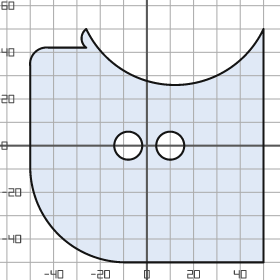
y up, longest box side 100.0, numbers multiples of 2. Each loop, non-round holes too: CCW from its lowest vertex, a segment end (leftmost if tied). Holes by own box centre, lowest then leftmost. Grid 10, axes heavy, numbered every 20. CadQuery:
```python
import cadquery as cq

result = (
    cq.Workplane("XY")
    .moveTo(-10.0, -50.0)
    .lineTo(50.0, -50.0)
    .lineTo(50.0, 50.0)
    .threePointArc((12.0, 26.0), (-26.0, 50.0))
    .threePointArc((-28.0, 46.0), (-26.0, 42.0))
    .lineTo(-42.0, 42.0)
    .threePointArc((-48.0, 40.0), (-50.0, 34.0))
    .lineTo(-50.0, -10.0)
    .threePointArc((-38.0, -38.0), (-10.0, -50.0))
    .close()
    .moveTo(-8.0, 0.0)
    .circle(6.0)
    .moveTo(10.0, 0.0)
    .circle(6.0)
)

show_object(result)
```